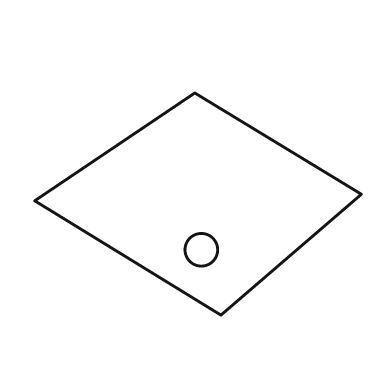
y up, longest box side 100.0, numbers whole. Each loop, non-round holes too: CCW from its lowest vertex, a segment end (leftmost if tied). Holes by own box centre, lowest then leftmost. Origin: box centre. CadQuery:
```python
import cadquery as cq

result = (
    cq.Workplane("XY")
    .moveTo(7.0, -34.0)
    .lineTo(50.0, 3.0)
    .lineTo(-1.0, 34.0)
    .lineTo(-50.0, 1.0)
    .close()
    .moveTo(1.0, -14.0)
    .circle(5.0)
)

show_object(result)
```